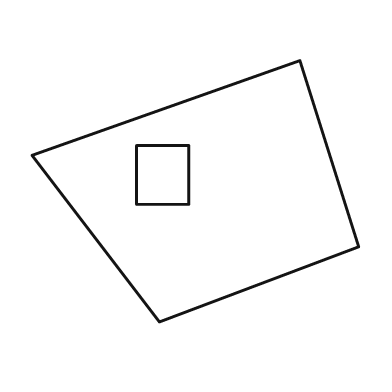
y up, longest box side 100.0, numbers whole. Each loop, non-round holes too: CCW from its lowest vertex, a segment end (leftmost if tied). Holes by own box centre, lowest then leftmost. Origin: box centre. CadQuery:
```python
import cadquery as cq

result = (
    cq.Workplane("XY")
    .moveTo(-11.0, -40.0)
    .lineTo(50.0, -17.0)
    .lineTo(32.0, 40.0)
    .lineTo(-50.0, 11.0)
    .close()
    .moveTo(-18.0, -4.0)
    .lineTo(-2.0, -4.0)
    .lineTo(-2.0, 14.0)
    .lineTo(-18.0, 14.0)
    .close()
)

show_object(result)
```